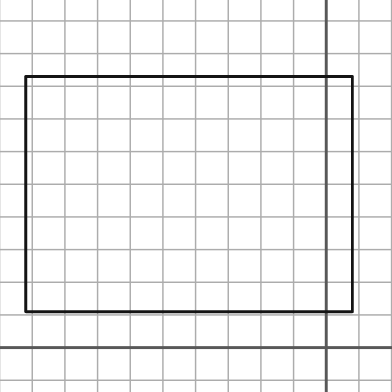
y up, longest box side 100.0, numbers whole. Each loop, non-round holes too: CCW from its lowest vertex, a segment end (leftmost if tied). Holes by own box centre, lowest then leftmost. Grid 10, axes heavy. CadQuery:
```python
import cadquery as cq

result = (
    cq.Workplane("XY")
    .moveTo(-92.0, 11.0)
    .lineTo(8.0, 11.0)
    .lineTo(8.0, 83.0)
    .lineTo(-92.0, 83.0)
    .close()
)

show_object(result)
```